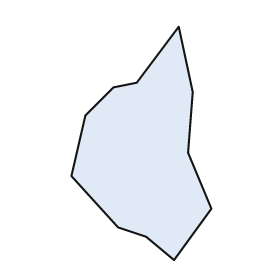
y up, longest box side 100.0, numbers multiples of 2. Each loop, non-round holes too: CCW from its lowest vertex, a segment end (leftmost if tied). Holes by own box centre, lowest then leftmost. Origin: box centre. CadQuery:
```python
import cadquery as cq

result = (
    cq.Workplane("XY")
    .moveTo(14.0, -50.0)
    .lineTo(30.0, -28.0)
    .lineTo(20.0, -4.0)
    .lineTo(22.0, 22.0)
    .lineTo(16.0, 50.0)
    .lineTo(-2.0, 26.0)
    .lineTo(-12.0, 24.0)
    .lineTo(-24.0, 12.0)
    .lineTo(-30.0, -14.0)
    .lineTo(-10.0, -36.0)
    .lineTo(2.0, -40.0)
    .close()
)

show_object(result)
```